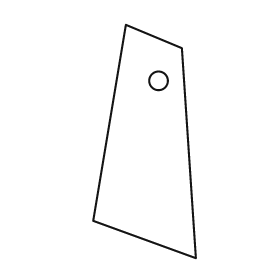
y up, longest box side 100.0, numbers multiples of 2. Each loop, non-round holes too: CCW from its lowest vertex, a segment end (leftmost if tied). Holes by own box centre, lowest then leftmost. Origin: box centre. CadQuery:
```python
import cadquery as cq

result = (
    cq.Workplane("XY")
    .moveTo(22.0, -50.0)
    .lineTo(16.0, 40.0)
    .lineTo(-8.0, 50.0)
    .lineTo(-22.0, -34.0)
    .close()
    .moveTo(6.0, 26.0)
    .circle(4.0)
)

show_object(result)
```